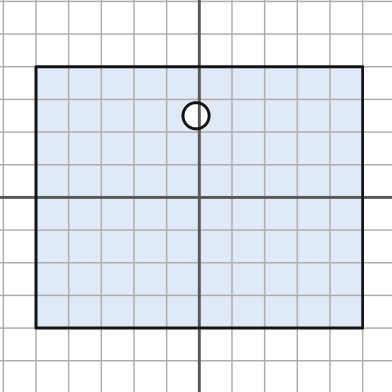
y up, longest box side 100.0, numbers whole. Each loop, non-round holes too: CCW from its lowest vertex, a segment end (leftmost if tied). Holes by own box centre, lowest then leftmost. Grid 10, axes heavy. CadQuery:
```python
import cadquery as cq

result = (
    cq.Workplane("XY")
    .moveTo(-50.0, -40.0)
    .lineTo(50.0, -40.0)
    .lineTo(50.0, 40.0)
    .lineTo(-50.0, 40.0)
    .close()
    .moveTo(-1.0, 25.0)
    .circle(4.0)
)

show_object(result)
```